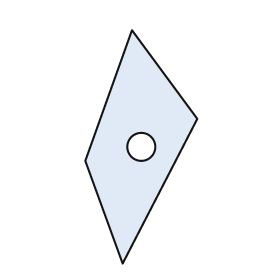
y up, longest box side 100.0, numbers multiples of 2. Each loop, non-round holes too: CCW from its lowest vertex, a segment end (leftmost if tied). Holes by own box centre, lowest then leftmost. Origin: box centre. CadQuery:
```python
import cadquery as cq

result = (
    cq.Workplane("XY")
    .moveTo(-8.0, -50.0)
    .lineTo(24.0, 12.0)
    .lineTo(-4.0, 50.0)
    .lineTo(-24.0, -6.0)
    .close()
    .moveTo(0.0, 0.0)
    .circle(6.0)
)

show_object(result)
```